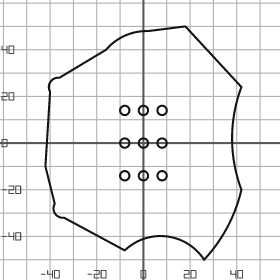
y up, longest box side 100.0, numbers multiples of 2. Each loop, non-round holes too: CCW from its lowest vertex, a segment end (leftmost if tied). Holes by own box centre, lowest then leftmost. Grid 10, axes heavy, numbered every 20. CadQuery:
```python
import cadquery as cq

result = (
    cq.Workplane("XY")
    .moveTo(26.0, -50.0)
    .threePointArc((36.0, -36.0), (42.0, -20.0))
    .threePointArc((38.0, 2.0), (42.0, 24.0))
    .lineTo(18.0, 50.0)
    .lineTo(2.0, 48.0)
    .threePointArc((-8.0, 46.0), (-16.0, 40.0))
    .lineTo(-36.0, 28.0)
    .threePointArc((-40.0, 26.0), (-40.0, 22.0))
    .lineTo(-42.0, -10.0)
    .lineTo(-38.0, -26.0)
    .threePointArc((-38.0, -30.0), (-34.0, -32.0))
    .lineTo(-8.0, -46.0)
    .threePointArc((10.0, -40.0), (26.0, -50.0))
    .close()
    .moveTo(-8.0, -14.0)
    .circle(2.0)
    .moveTo(0.0, -14.0)
    .circle(2.0)
    .moveTo(8.0, -14.0)
    .circle(2.0)
    .moveTo(-8.0, 0.0)
    .circle(2.0)
    .moveTo(0.0, 0.0)
    .circle(2.0)
    .moveTo(8.0, 0.0)
    .circle(2.0)
    .moveTo(-8.0, 14.0)
    .circle(2.0)
    .moveTo(0.0, 14.0)
    .circle(2.0)
    .moveTo(8.0, 14.0)
    .circle(2.0)
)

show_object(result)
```